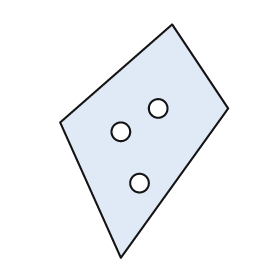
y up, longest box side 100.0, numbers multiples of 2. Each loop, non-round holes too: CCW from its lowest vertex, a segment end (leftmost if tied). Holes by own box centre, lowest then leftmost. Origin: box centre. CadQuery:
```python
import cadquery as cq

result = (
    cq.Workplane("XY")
    .moveTo(-10.0, -50.0)
    .lineTo(36.0, 14.0)
    .lineTo(12.0, 50.0)
    .lineTo(-36.0, 8.0)
    .close()
    .moveTo(-2.0, -18.0)
    .circle(4.0)
    .moveTo(-10.0, 4.0)
    .circle(4.0)
    .moveTo(6.0, 14.0)
    .circle(4.0)
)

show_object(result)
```